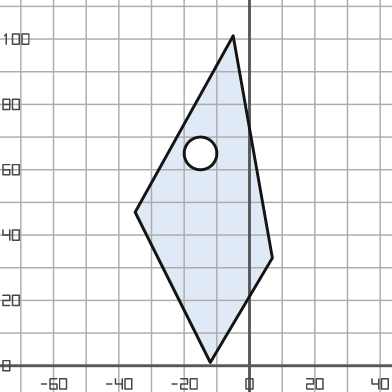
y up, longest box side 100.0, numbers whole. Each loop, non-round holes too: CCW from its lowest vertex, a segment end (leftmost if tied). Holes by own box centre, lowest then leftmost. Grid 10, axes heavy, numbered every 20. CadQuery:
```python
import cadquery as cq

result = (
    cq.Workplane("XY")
    .moveTo(-12.0, 1.0)
    .lineTo(7.0, 33.0)
    .lineTo(-5.0, 101.0)
    .lineTo(-35.0, 47.0)
    .close()
    .moveTo(-15.0, 65.0)
    .circle(5.0)
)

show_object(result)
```